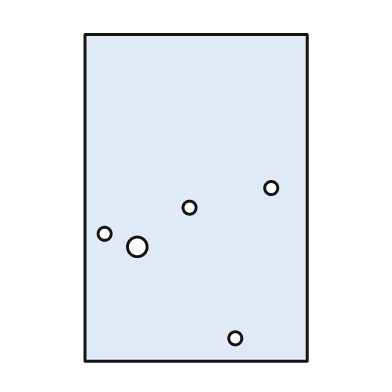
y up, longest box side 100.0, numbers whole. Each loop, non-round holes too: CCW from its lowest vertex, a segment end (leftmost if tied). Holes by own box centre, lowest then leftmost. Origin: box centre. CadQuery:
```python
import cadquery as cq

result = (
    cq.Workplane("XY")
    .moveTo(-34.0, -50.0)
    .lineTo(34.0, -50.0)
    .lineTo(34.0, 50.0)
    .lineTo(-34.0, 50.0)
    .close()
    .moveTo(12.0, -43.0)
    .circle(2.0)
    .moveTo(-18.0, -15.0)
    .circle(3.0)
    .moveTo(-28.0, -11.0)
    .circle(2.0)
    .moveTo(-2.0, -3.0)
    .circle(2.0)
    .moveTo(23.0, 3.0)
    .circle(2.0)
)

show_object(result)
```